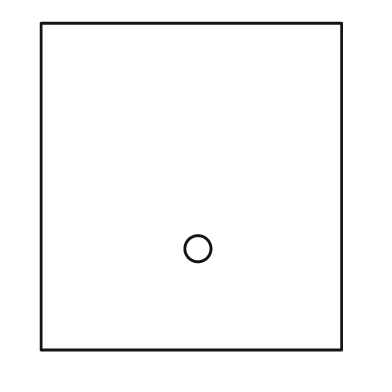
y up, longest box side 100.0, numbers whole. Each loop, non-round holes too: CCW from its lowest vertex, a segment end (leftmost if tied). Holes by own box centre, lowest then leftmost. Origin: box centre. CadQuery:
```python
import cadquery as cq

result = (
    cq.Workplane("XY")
    .moveTo(-46.0, -50.0)
    .lineTo(46.0, -50.0)
    .lineTo(46.0, 50.0)
    .lineTo(-46.0, 50.0)
    .close()
    .moveTo(2.0, -19.0)
    .circle(4.0)
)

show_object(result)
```